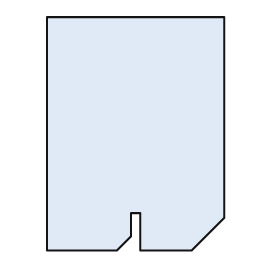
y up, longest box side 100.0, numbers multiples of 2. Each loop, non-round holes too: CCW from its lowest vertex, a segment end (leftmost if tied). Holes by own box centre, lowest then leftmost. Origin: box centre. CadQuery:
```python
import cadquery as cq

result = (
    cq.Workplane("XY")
    .moveTo(-38.0, -50.0)
    .lineTo(-8.0, -50.0)
    .lineTo(-2.0, -44.0)
    .lineTo(-2.0, -34.0)
    .lineTo(2.0, -34.0)
    .lineTo(2.0, -50.0)
    .lineTo(24.0, -50.0)
    .lineTo(38.0, -36.0)
    .lineTo(38.0, 50.0)
    .lineTo(-38.0, 50.0)
    .close()
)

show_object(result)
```